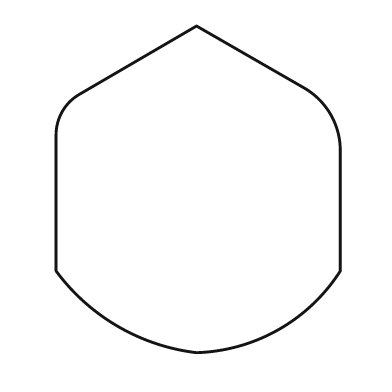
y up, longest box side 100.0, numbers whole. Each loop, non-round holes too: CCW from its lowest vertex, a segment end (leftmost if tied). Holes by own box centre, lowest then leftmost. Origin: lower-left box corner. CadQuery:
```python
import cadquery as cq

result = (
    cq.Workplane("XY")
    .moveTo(43.0, 0.0)
    .threePointArc((68.0, 7.0), (87.0, 25.0))
    .lineTo(87.0, 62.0)
    .threePointArc((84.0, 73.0), (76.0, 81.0))
    .lineTo(43.0, 100.0)
    .lineTo(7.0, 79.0)
    .threePointArc((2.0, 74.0), (0.0, 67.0))
    .lineTo(0.0, 25.0)
    .threePointArc((19.0, 8.0), (43.0, 0.0))
    .close()
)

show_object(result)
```